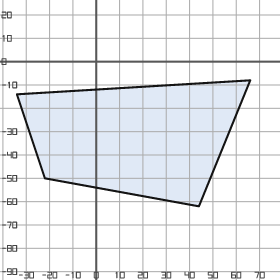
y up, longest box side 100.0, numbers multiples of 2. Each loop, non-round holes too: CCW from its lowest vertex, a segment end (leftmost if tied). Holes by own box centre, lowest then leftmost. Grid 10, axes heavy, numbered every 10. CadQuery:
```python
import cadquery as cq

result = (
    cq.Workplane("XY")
    .moveTo(44.0, -62.0)
    .lineTo(66.0, -8.0)
    .lineTo(-34.0, -14.0)
    .lineTo(-22.0, -50.0)
    .close()
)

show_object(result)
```